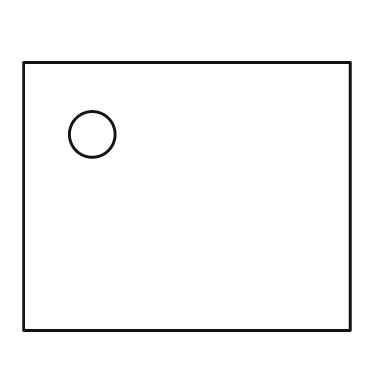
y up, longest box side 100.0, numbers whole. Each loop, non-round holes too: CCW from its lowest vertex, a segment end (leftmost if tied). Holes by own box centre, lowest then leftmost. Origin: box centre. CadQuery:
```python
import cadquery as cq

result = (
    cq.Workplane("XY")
    .moveTo(-50.0, -41.0)
    .lineTo(50.0, -41.0)
    .lineTo(50.0, 41.0)
    .lineTo(-50.0, 41.0)
    .close()
    .moveTo(-29.0, 19.0)
    .circle(7.0)
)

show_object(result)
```